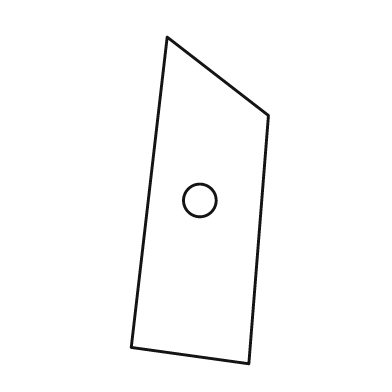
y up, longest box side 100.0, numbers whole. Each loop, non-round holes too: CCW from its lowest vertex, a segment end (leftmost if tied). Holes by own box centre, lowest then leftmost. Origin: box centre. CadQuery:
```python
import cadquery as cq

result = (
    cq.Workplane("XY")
    .moveTo(15.0, -50.0)
    .lineTo(21.0, 26.0)
    .lineTo(-10.0, 50.0)
    .lineTo(-21.0, -45.0)
    .close()
    .moveTo(0.0, 0.0)
    .circle(5.0)
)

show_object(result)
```